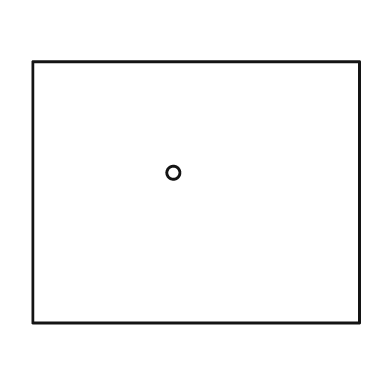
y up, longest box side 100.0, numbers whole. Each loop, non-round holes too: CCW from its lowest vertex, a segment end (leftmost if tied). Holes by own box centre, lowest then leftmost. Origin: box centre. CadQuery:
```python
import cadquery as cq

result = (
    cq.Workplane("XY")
    .moveTo(-50.0, -40.0)
    .lineTo(50.0, -40.0)
    .lineTo(50.0, 40.0)
    .lineTo(-50.0, 40.0)
    .close()
    .moveTo(-7.0, 6.0)
    .circle(2.0)
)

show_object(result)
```